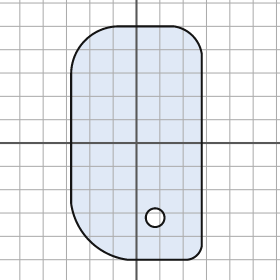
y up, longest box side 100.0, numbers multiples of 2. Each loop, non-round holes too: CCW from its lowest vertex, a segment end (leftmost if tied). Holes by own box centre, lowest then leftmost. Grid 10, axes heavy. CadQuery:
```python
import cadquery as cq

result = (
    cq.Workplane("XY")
    .moveTo(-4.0, -50.0)
    .lineTo(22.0, -50.0)
    .threePointArc((26.0, -48.0), (28.0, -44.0))
    .lineTo(28.0, 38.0)
    .threePointArc((24.0, 46.0), (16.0, 50.0))
    .lineTo(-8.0, 50.0)
    .threePointArc((-22.0, 44.0), (-28.0, 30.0))
    .lineTo(-28.0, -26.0)
    .threePointArc((-20.0, -42.0), (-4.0, -50.0))
    .close()
    .moveTo(8.0, -32.0)
    .circle(4.0)
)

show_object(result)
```